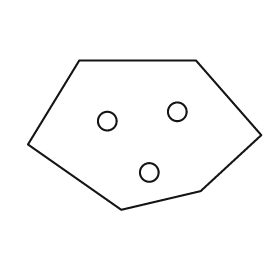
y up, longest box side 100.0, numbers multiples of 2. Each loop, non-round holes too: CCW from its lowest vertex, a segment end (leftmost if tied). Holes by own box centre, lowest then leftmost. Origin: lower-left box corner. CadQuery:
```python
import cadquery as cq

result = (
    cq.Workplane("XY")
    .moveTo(40.0, 0.0)
    .lineTo(74.0, 8.0)
    .lineTo(100.0, 32.0)
    .lineTo(72.0, 64.0)
    .lineTo(22.0, 64.0)
    .lineTo(0.0, 28.0)
    .close()
    .moveTo(52.0, 16.0)
    .circle(4.0)
    .moveTo(34.0, 38.0)
    .circle(4.0)
    .moveTo(64.0, 42.0)
    .circle(4.0)
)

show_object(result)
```